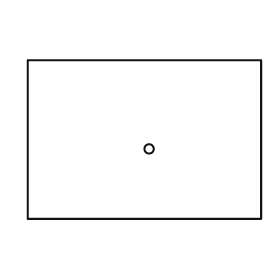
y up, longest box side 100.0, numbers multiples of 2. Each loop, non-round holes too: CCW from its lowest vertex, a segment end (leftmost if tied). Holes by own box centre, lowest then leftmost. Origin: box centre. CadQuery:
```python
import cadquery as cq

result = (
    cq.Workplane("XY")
    .moveTo(-50.0, -34.0)
    .lineTo(50.0, -34.0)
    .lineTo(50.0, 34.0)
    .lineTo(-50.0, 34.0)
    .close()
    .moveTo(2.0, -4.0)
    .circle(2.0)
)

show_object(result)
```